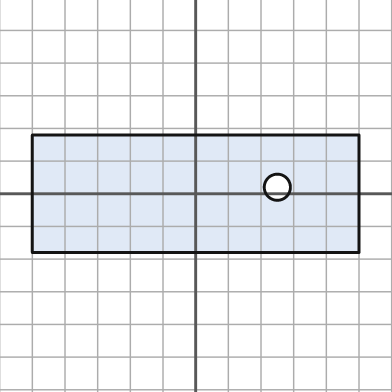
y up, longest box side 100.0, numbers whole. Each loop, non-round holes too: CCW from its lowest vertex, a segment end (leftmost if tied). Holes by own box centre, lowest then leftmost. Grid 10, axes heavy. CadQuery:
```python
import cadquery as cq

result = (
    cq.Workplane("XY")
    .moveTo(-50.0, -18.0)
    .lineTo(50.0, -18.0)
    .lineTo(50.0, 18.0)
    .lineTo(-50.0, 18.0)
    .close()
    .moveTo(25.0, 2.0)
    .circle(4.0)
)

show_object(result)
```